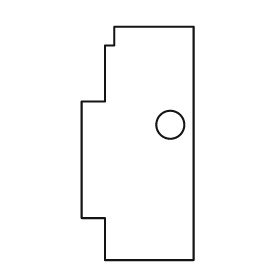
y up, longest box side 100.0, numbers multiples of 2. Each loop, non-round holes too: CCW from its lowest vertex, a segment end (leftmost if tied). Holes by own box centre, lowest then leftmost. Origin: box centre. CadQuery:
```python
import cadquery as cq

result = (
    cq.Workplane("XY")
    .moveTo(-14.0, -50.0)
    .lineTo(24.0, -50.0)
    .lineTo(24.0, 50.0)
    .lineTo(-10.0, 50.0)
    .lineTo(-10.0, 42.0)
    .lineTo(-14.0, 42.0)
    .lineTo(-14.0, 18.0)
    .lineTo(-24.0, 18.0)
    .lineTo(-24.0, -32.0)
    .lineTo(-14.0, -32.0)
    .close()
    .moveTo(14.0, 8.0)
    .circle(6.0)
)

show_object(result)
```